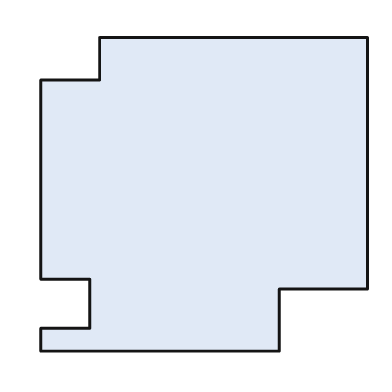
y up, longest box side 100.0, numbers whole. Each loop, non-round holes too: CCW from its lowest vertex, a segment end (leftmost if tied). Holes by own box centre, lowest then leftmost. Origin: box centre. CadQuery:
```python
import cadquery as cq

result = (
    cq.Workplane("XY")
    .moveTo(-50.0, -48.0)
    .lineTo(23.0, -48.0)
    .lineTo(23.0, -29.0)
    .lineTo(50.0, -29.0)
    .lineTo(50.0, 48.0)
    .lineTo(-32.0, 48.0)
    .lineTo(-32.0, 35.0)
    .lineTo(-50.0, 35.0)
    .lineTo(-50.0, -26.0)
    .lineTo(-35.0, -26.0)
    .lineTo(-35.0, -41.0)
    .lineTo(-50.0, -41.0)
    .close()
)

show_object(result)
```